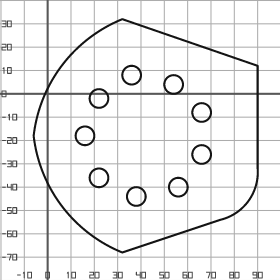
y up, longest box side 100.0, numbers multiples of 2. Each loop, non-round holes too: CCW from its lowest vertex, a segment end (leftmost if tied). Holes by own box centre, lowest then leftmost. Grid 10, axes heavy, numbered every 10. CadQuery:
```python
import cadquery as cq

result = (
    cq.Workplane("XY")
    .moveTo(32.0, -68.0)
    .lineTo(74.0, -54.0)
    .threePointArc((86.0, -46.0), (90.0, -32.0))
    .lineTo(90.0, 12.0)
    .lineTo(32.0, 32.0)
    .threePointArc((6.0, 12.0), (-6.0, -18.0))
    .threePointArc((6.0, -48.0), (32.0, -68.0))
    .close()
    .moveTo(38.0, -44.0)
    .circle(4.0)
    .moveTo(56.0, -40.0)
    .circle(4.0)
    .moveTo(22.0, -36.0)
    .circle(4.0)
    .moveTo(66.0, -26.0)
    .circle(4.0)
    .moveTo(16.0, -18.0)
    .circle(4.0)
    .moveTo(66.0, -8.0)
    .circle(4.0)
    .moveTo(22.0, -2.0)
    .circle(4.0)
    .moveTo(54.0, 4.0)
    .circle(4.0)
    .moveTo(36.0, 8.0)
    .circle(4.0)
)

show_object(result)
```